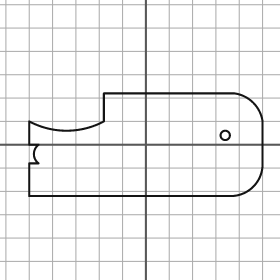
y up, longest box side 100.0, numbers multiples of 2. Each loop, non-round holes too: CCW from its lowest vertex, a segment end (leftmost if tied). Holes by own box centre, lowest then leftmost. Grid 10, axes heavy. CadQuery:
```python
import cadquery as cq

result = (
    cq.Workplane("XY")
    .moveTo(-50.0, -22.0)
    .lineTo(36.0, -22.0)
    .threePointArc((46.0, -18.0), (50.0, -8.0))
    .lineTo(50.0, 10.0)
    .threePointArc((46.0, 18.0), (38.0, 22.0))
    .lineTo(-18.0, 22.0)
    .lineTo(-18.0, 10.0)
    .threePointArc((-34.0, 6.0), (-50.0, 10.0))
    .lineTo(-50.0, 0.0)
    .lineTo(-46.0, 0.0)
    .threePointArc((-48.0, -4.0), (-46.0, -8.0))
    .lineTo(-50.0, -8.0)
    .close()
    .moveTo(34.0, 4.0)
    .circle(2.0)
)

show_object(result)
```